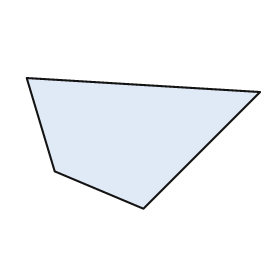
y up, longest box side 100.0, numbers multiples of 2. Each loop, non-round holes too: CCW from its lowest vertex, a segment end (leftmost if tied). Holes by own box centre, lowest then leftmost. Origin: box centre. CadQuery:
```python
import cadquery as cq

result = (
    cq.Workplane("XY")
    .moveTo(0.0, -28.0)
    .lineTo(50.0, 22.0)
    .lineTo(-50.0, 28.0)
    .lineTo(-38.0, -12.0)
    .close()
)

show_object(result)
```